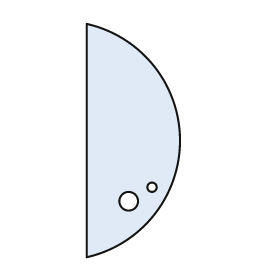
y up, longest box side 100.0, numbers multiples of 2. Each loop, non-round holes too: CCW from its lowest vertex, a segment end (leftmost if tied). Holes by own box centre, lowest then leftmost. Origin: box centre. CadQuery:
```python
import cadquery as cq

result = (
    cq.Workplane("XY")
    .moveTo(-20.0, -50.0)
    .threePointArc((20.0, 0.0), (-20.0, 50.0))
    .close()
    .moveTo(-2.0, -26.0)
    .circle(4.0)
    .moveTo(8.0, -20.0)
    .circle(2.0)
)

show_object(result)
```